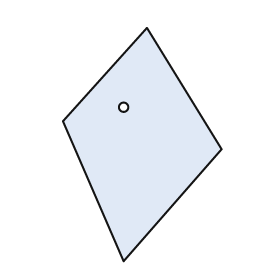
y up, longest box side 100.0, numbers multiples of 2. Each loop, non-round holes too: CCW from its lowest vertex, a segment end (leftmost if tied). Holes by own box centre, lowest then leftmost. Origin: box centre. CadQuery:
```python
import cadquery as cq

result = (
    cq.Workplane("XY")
    .moveTo(-8.0, -50.0)
    .lineTo(34.0, -2.0)
    .lineTo(2.0, 50.0)
    .lineTo(-34.0, 10.0)
    .close()
    .moveTo(-8.0, 16.0)
    .circle(2.0)
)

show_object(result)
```